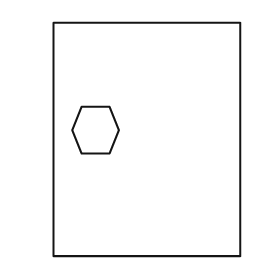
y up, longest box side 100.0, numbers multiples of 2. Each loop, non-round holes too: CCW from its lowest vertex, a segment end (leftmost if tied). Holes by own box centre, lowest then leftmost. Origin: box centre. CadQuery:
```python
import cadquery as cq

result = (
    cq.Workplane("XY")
    .moveTo(-40.0, -50.0)
    .lineTo(40.0, -50.0)
    .lineTo(40.0, 50.0)
    .lineTo(-40.0, 50.0)
    .close()
    .moveTo(-28.0, -6.0)
    .lineTo(-16.0, -6.0)
    .lineTo(-12.0, 4.0)
    .lineTo(-16.0, 14.0)
    .lineTo(-28.0, 14.0)
    .lineTo(-32.0, 4.0)
    .close()
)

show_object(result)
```